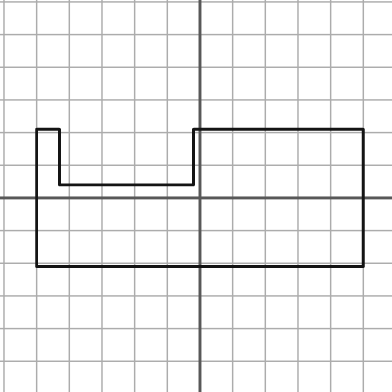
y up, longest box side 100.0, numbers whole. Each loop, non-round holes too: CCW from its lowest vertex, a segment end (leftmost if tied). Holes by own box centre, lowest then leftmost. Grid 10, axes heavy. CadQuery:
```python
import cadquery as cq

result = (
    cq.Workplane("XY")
    .moveTo(-50.0, -21.0)
    .lineTo(50.0, -21.0)
    .lineTo(50.0, 21.0)
    .lineTo(-2.0, 21.0)
    .lineTo(-2.0, 4.0)
    .lineTo(-43.0, 4.0)
    .lineTo(-43.0, 21.0)
    .lineTo(-50.0, 21.0)
    .close()
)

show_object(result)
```